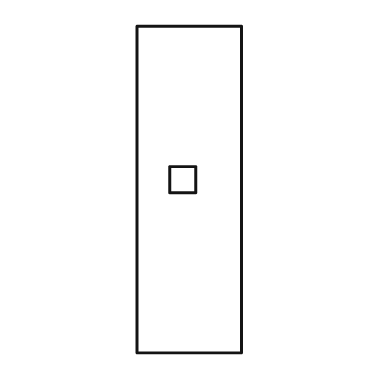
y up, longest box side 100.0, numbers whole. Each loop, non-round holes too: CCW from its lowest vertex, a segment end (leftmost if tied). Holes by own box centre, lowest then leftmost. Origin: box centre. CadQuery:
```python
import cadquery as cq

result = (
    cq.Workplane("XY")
    .moveTo(-16.0, -50.0)
    .lineTo(16.0, -50.0)
    .lineTo(16.0, 50.0)
    .lineTo(-16.0, 50.0)
    .close()
    .moveTo(-6.0, -1.0)
    .lineTo(2.0, -1.0)
    .lineTo(2.0, 7.0)
    .lineTo(-6.0, 7.0)
    .close()
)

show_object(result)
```